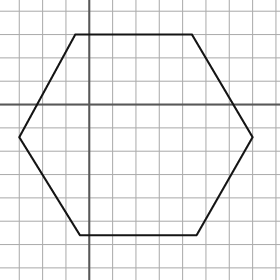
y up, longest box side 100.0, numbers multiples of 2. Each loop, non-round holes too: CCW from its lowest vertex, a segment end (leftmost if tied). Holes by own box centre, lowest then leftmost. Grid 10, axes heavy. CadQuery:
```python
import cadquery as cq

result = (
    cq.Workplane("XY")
    .moveTo(-4.0, -56.0)
    .lineTo(46.0, -56.0)
    .lineTo(70.0, -14.0)
    .lineTo(44.0, 30.0)
    .lineTo(-6.0, 30.0)
    .lineTo(-30.0, -14.0)
    .close()
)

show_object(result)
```